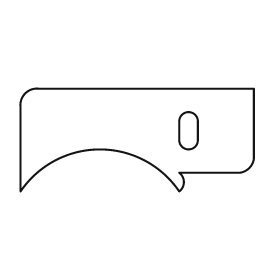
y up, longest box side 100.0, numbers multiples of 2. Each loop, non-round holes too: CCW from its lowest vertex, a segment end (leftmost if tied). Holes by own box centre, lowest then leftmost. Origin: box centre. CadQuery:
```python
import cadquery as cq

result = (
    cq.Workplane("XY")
    .moveTo(-50.0, -22.0)
    .threePointArc((-16.0, -4.0), (18.0, -22.0))
    .threePointArc((20.0, -18.0), (18.0, -14.0))
    .lineTo(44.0, -14.0)
    .threePointArc((48.0, -12.0), (50.0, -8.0))
    .lineTo(50.0, 22.0)
    .lineTo(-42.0, 22.0)
    .threePointArc((-48.0, 20.0), (-50.0, 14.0))
    .close()
    .moveTo(18.0, 0.0)
    .threePointArc((22.0, -4.0), (26.0, 0.0))
    .lineTo(26.0, 8.0)
    .threePointArc((22.0, 12.0), (18.0, 8.0))
    .close()
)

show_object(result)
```